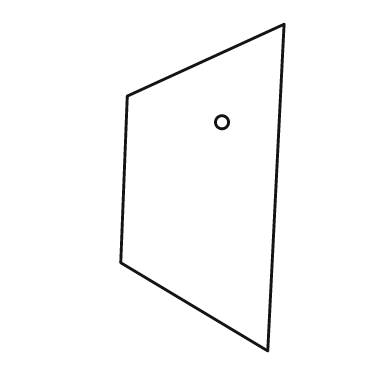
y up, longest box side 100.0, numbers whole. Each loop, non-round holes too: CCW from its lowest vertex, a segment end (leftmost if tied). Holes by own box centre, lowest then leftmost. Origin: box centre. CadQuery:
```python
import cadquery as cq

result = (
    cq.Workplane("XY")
    .moveTo(20.0, -50.0)
    .lineTo(25.0, 50.0)
    .lineTo(-23.0, 28.0)
    .lineTo(-25.0, -23.0)
    .close()
    .moveTo(6.0, 20.0)
    .circle(2.0)
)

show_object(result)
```